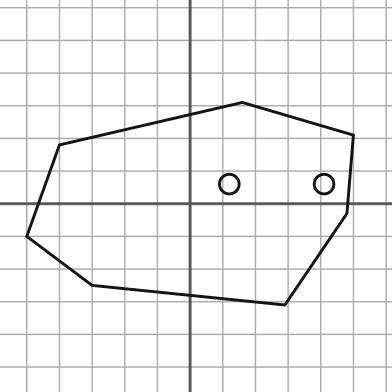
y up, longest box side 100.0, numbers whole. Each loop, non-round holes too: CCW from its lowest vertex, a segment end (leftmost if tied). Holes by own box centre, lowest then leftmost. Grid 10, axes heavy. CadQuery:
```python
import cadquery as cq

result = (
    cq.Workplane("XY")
    .moveTo(29.0, -31.0)
    .lineTo(48.0, -3.0)
    .lineTo(50.0, 21.0)
    .lineTo(16.0, 31.0)
    .lineTo(-40.0, 18.0)
    .lineTo(-50.0, -10.0)
    .lineTo(-30.0, -25.0)
    .close()
    .moveTo(12.0, 6.0)
    .circle(3.0)
    .moveTo(41.0, 6.0)
    .circle(3.0)
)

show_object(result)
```